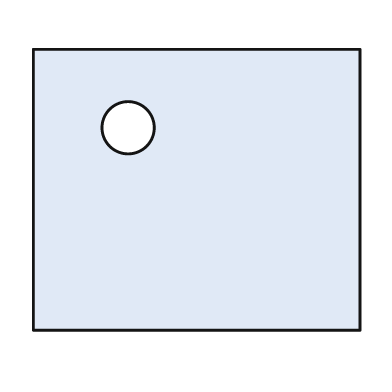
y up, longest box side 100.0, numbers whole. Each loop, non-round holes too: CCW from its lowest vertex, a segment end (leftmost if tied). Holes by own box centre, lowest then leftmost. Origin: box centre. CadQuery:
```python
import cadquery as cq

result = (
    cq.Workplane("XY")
    .moveTo(-50.0, -43.0)
    .lineTo(50.0, -43.0)
    .lineTo(50.0, 43.0)
    .lineTo(-50.0, 43.0)
    .close()
    .moveTo(-21.0, 19.0)
    .circle(8.0)
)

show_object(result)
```